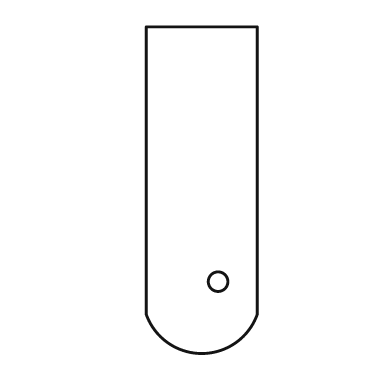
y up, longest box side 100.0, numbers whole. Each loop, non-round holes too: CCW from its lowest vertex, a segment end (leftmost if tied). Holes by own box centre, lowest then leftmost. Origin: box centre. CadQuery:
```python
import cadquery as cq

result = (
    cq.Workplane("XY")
    .moveTo(-17.0, -38.0)
    .threePointArc((0.0, -50.0), (17.0, -38.0))
    .lineTo(17.0, 50.0)
    .lineTo(-17.0, 50.0)
    .close()
    .moveTo(5.0, -28.0)
    .circle(3.0)
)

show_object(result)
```